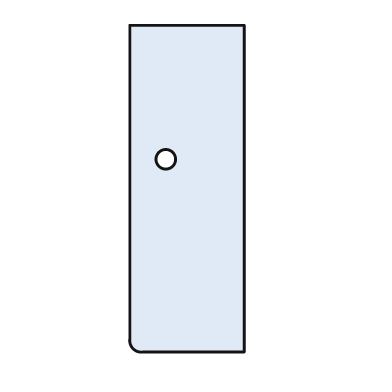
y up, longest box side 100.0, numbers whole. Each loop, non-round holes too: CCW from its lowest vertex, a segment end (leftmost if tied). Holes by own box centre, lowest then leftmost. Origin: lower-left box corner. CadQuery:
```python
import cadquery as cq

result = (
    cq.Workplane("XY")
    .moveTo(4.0, 0.0)
    .lineTo(35.0, 0.0)
    .lineTo(35.0, 100.0)
    .lineTo(0.0, 100.0)
    .lineTo(0.0, 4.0)
    .threePointArc((1.0, 1.0), (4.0, 0.0))
    .close()
    .moveTo(11.0, 59.0)
    .circle(3.0)
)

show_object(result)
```